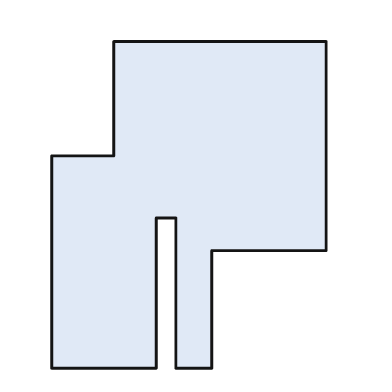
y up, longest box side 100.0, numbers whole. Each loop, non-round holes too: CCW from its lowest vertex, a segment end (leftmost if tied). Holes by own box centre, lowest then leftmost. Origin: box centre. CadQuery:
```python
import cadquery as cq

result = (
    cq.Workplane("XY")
    .moveTo(-42.0, -50.0)
    .lineTo(-10.0, -50.0)
    .lineTo(-10.0, -4.0)
    .lineTo(-4.0, -4.0)
    .lineTo(-4.0, -50.0)
    .lineTo(7.0, -50.0)
    .lineTo(7.0, -14.0)
    .lineTo(42.0, -14.0)
    .lineTo(42.0, 50.0)
    .lineTo(-23.0, 50.0)
    .lineTo(-23.0, 15.0)
    .lineTo(-42.0, 15.0)
    .close()
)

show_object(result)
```